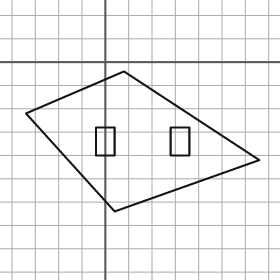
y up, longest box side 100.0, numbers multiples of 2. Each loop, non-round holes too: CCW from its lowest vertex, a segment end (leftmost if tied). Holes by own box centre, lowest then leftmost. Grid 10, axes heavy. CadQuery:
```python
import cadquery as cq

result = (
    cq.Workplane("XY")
    .moveTo(4.0, -64.0)
    .lineTo(66.0, -42.0)
    .lineTo(8.0, -4.0)
    .lineTo(-34.0, -22.0)
    .close()
    .moveTo(-4.0, -40.0)
    .lineTo(4.0, -40.0)
    .lineTo(4.0, -28.0)
    .lineTo(-4.0, -28.0)
    .close()
    .moveTo(28.0, -40.0)
    .lineTo(36.0, -40.0)
    .lineTo(36.0, -28.0)
    .lineTo(28.0, -28.0)
    .close()
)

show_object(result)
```